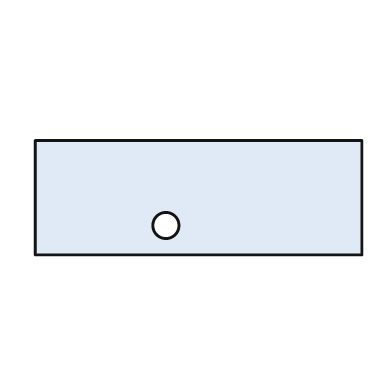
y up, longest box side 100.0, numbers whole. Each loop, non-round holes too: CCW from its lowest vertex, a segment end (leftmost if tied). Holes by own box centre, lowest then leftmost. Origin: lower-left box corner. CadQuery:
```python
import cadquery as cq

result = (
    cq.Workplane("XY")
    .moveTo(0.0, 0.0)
    .lineTo(100.0, 0.0)
    .lineTo(100.0, 35.0)
    .lineTo(0.0, 35.0)
    .close()
    .moveTo(40.0, 9.0)
    .circle(4.0)
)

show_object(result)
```